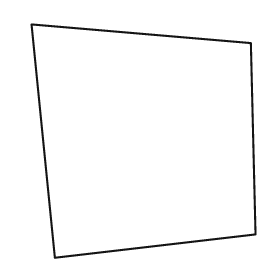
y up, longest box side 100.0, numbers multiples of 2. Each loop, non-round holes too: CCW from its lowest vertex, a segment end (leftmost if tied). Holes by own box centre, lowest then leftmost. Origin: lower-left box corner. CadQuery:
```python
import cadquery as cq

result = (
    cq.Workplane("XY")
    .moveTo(10.0, 0.0)
    .lineTo(96.0, 10.0)
    .lineTo(94.0, 92.0)
    .lineTo(0.0, 100.0)
    .close()
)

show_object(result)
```